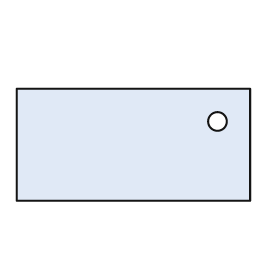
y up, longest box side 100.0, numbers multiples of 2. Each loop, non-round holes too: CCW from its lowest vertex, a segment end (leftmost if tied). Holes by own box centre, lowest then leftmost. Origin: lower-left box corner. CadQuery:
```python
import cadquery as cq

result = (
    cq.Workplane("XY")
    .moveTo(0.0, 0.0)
    .lineTo(100.0, 0.0)
    .lineTo(100.0, 48.0)
    .lineTo(0.0, 48.0)
    .close()
    .moveTo(86.0, 34.0)
    .circle(4.0)
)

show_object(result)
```